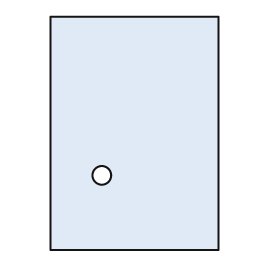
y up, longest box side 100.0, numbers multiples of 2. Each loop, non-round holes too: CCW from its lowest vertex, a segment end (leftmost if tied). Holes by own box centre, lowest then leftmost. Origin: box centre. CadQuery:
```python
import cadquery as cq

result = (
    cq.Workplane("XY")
    .moveTo(-36.0, -50.0)
    .lineTo(36.0, -50.0)
    .lineTo(36.0, 50.0)
    .lineTo(-36.0, 50.0)
    .close()
    .moveTo(-14.0, -18.0)
    .circle(4.0)
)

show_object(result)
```